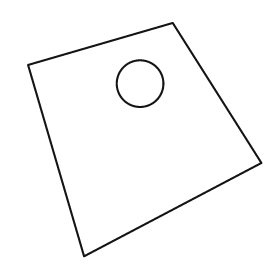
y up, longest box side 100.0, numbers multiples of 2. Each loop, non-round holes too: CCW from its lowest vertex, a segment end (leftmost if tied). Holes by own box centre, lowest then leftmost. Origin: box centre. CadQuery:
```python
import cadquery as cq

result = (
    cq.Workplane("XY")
    .moveTo(-26.0, -50.0)
    .lineTo(50.0, -10.0)
    .lineTo(12.0, 50.0)
    .lineTo(-50.0, 32.0)
    .close()
    .moveTo(-2.0, 24.0)
    .circle(10.0)
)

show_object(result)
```